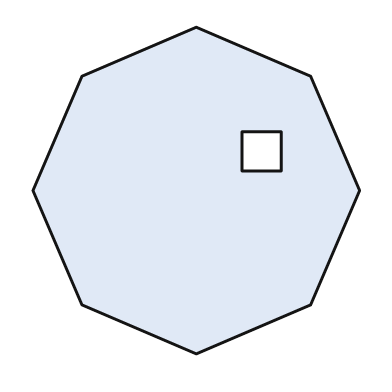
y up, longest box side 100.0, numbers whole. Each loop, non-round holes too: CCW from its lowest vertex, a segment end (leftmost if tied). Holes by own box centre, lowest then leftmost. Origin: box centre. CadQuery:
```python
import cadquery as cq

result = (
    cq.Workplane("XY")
    .moveTo(0.0, -50.0)
    .lineTo(35.0, -35.0)
    .lineTo(50.0, 0.0)
    .lineTo(35.0, 35.0)
    .lineTo(0.0, 50.0)
    .lineTo(-35.0, 35.0)
    .lineTo(-50.0, 0.0)
    .lineTo(-35.0, -35.0)
    .close()
    .moveTo(14.0, 6.0)
    .lineTo(26.0, 6.0)
    .lineTo(26.0, 18.0)
    .lineTo(14.0, 18.0)
    .close()
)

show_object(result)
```